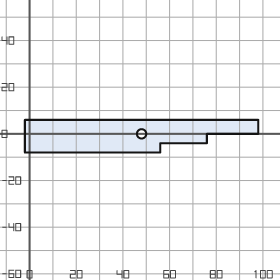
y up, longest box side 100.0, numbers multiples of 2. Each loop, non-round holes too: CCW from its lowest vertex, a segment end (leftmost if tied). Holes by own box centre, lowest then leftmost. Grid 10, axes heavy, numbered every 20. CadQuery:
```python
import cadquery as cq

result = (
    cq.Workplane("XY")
    .moveTo(-2.0, -8.0)
    .lineTo(56.0, -8.0)
    .lineTo(56.0, -4.0)
    .lineTo(76.0, -4.0)
    .lineTo(76.0, 0.0)
    .lineTo(98.0, 0.0)
    .lineTo(98.0, 6.0)
    .lineTo(-2.0, 6.0)
    .close()
    .moveTo(48.0, 0.0)
    .circle(2.0)
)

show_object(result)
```